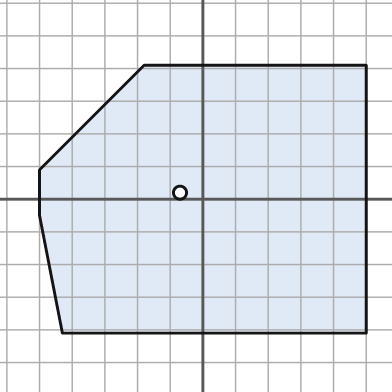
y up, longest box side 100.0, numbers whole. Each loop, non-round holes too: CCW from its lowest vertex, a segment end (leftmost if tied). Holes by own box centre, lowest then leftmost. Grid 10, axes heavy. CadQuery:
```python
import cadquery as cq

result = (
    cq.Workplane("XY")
    .moveTo(-43.0, -41.0)
    .lineTo(50.0, -41.0)
    .lineTo(50.0, 41.0)
    .lineTo(-18.0, 41.0)
    .lineTo(-50.0, 9.0)
    .lineTo(-50.0, -5.0)
    .close()
    .moveTo(-7.0, 2.0)
    .circle(2.0)
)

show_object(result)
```